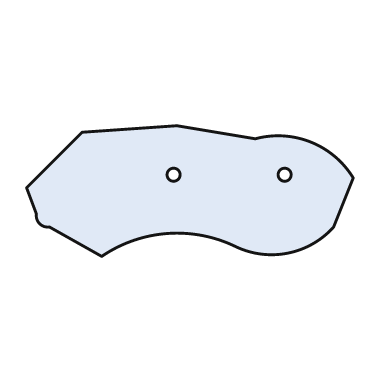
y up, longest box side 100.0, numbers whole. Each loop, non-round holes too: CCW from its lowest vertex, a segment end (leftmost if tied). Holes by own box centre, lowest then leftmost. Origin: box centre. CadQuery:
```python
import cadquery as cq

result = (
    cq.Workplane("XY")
    .moveTo(-27.0, -20.0)
    .threePointArc((-7.0, -13.0), (14.0, -17.0))
    .threePointArc((30.0, -19.0), (44.0, -11.0))
    .lineTo(50.0, 4.0)
    .threePointArc((37.0, 15.0), (20.0, 16.0))
    .lineTo(-4.0, 20.0)
    .lineTo(-33.0, 18.0)
    .lineTo(-50.0, 1.0)
    .lineTo(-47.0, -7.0)
    .threePointArc((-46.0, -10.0), (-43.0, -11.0))
    .close()
    .moveTo(-5.0, 5.0)
    .circle(2.0)
    .moveTo(29.0, 5.0)
    .circle(2.0)
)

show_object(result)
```